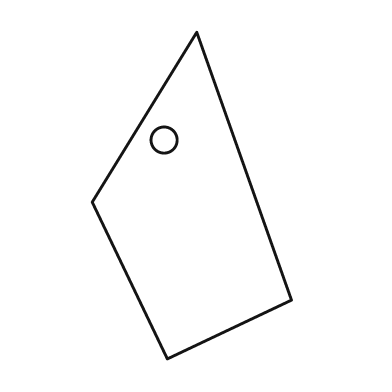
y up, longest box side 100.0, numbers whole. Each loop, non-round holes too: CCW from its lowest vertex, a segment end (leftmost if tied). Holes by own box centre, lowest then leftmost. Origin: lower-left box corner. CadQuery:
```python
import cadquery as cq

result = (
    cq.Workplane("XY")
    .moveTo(23.0, 0.0)
    .lineTo(61.0, 18.0)
    .lineTo(32.0, 100.0)
    .lineTo(0.0, 48.0)
    .close()
    .moveTo(22.0, 67.0)
    .circle(4.0)
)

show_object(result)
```